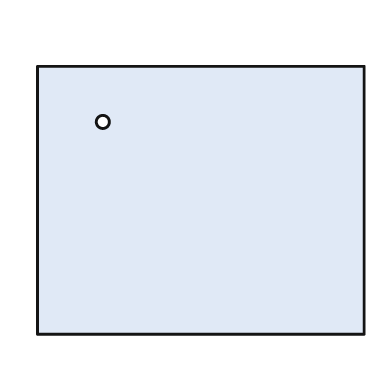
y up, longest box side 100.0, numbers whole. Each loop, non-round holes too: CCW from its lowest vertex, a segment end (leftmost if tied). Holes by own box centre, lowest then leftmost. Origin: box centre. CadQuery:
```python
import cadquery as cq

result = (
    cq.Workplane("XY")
    .moveTo(-50.0, -41.0)
    .lineTo(50.0, -41.0)
    .lineTo(50.0, 41.0)
    .lineTo(-50.0, 41.0)
    .close()
    .moveTo(-30.0, 24.0)
    .circle(2.0)
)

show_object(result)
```